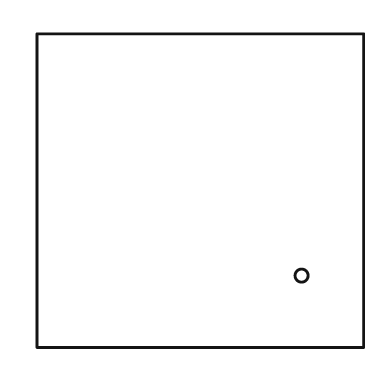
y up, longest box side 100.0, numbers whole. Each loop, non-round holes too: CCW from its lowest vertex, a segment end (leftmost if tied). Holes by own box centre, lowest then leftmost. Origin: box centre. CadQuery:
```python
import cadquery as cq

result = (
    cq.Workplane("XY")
    .moveTo(-50.0, -48.0)
    .lineTo(50.0, -48.0)
    .lineTo(50.0, 48.0)
    .lineTo(-50.0, 48.0)
    .close()
    .moveTo(31.0, -26.0)
    .circle(2.0)
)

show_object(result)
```